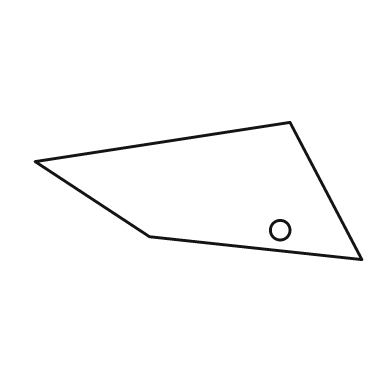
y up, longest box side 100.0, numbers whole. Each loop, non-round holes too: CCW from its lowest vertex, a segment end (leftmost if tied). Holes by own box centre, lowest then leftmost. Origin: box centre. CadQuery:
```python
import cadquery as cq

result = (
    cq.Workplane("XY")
    .moveTo(50.0, -21.0)
    .lineTo(28.0, 21.0)
    .lineTo(-50.0, 9.0)
    .lineTo(-15.0, -14.0)
    .close()
    .moveTo(25.0, -12.0)
    .circle(3.0)
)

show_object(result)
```